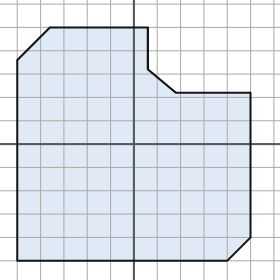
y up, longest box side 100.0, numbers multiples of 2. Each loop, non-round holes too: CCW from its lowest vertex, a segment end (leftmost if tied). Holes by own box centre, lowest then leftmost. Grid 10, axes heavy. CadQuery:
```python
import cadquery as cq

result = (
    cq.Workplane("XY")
    .moveTo(-50.0, -50.0)
    .lineTo(40.0, -50.0)
    .lineTo(50.0, -40.0)
    .lineTo(50.0, 22.0)
    .lineTo(18.0, 22.0)
    .lineTo(6.0, 32.0)
    .lineTo(6.0, 50.0)
    .lineTo(-36.0, 50.0)
    .lineTo(-50.0, 36.0)
    .close()
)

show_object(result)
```